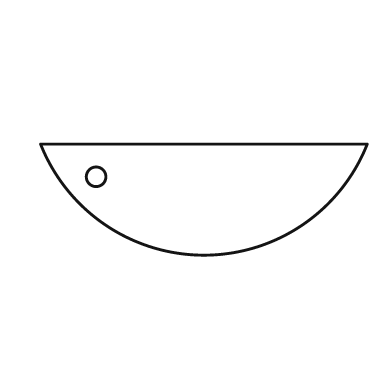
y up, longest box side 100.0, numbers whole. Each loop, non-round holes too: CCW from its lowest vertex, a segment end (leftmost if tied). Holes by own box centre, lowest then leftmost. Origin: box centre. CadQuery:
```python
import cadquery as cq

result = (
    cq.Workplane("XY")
    .moveTo(-50.0, 17.0)
    .threePointArc((0.0, -17.0), (50.0, 17.0))
    .close()
    .moveTo(-33.0, 7.0)
    .circle(3.0)
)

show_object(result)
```